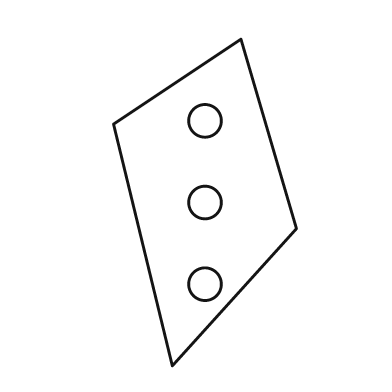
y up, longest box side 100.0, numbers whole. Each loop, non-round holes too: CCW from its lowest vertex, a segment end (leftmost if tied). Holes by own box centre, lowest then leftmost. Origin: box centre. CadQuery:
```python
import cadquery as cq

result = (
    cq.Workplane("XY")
    .moveTo(-10.0, -50.0)
    .lineTo(28.0, -8.0)
    .lineTo(11.0, 50.0)
    .lineTo(-28.0, 24.0)
    .close()
    .moveTo(0.0, -25.0)
    .circle(5.0)
    .moveTo(0.0, 0.0)
    .circle(5.0)
    .moveTo(0.0, 25.0)
    .circle(5.0)
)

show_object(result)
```